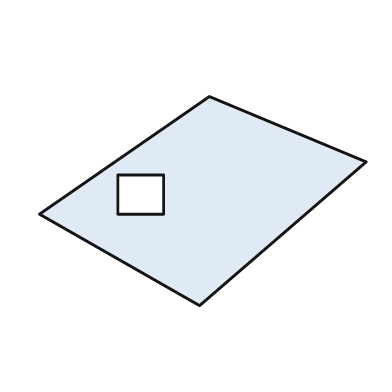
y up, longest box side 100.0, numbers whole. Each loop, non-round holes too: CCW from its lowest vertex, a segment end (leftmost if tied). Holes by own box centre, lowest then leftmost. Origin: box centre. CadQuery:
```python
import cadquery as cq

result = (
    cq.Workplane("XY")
    .moveTo(-1.0, -32.0)
    .lineTo(50.0, 12.0)
    .lineTo(2.0, 32.0)
    .lineTo(-50.0, -4.0)
    .close()
    .moveTo(-26.0, -4.0)
    .lineTo(-12.0, -4.0)
    .lineTo(-12.0, 8.0)
    .lineTo(-26.0, 8.0)
    .close()
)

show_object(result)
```